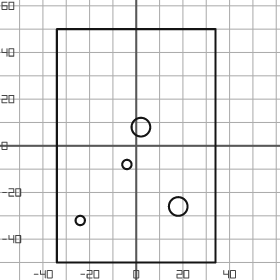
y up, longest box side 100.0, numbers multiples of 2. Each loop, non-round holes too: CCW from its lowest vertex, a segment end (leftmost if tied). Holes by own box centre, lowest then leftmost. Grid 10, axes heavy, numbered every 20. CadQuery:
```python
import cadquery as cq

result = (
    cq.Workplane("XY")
    .moveTo(-34.0, -50.0)
    .lineTo(34.0, -50.0)
    .lineTo(34.0, 50.0)
    .lineTo(-34.0, 50.0)
    .close()
    .moveTo(-24.0, -32.0)
    .circle(2.0)
    .moveTo(18.0, -26.0)
    .circle(4.0)
    .moveTo(-4.0, -8.0)
    .circle(2.0)
    .moveTo(2.0, 8.0)
    .circle(4.0)
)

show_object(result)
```